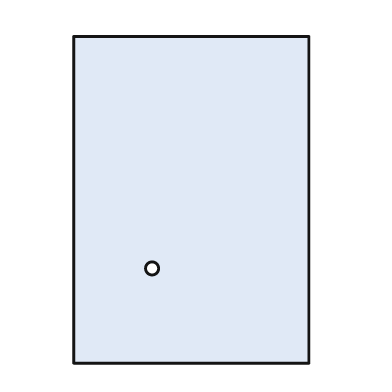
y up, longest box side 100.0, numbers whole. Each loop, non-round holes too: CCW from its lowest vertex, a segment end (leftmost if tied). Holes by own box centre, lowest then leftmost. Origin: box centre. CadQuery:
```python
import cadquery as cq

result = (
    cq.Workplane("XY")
    .moveTo(-36.0, -50.0)
    .lineTo(36.0, -50.0)
    .lineTo(36.0, 50.0)
    .lineTo(-36.0, 50.0)
    .close()
    .moveTo(-12.0, -21.0)
    .circle(2.0)
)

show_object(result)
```